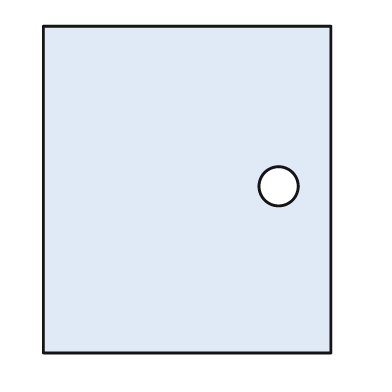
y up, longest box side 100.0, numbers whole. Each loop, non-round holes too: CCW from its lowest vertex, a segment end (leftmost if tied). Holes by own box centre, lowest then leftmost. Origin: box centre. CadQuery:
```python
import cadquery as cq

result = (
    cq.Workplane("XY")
    .moveTo(-44.0, -50.0)
    .lineTo(44.0, -50.0)
    .lineTo(44.0, 50.0)
    .lineTo(-44.0, 50.0)
    .close()
    .moveTo(28.0, 1.0)
    .circle(6.0)
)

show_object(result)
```